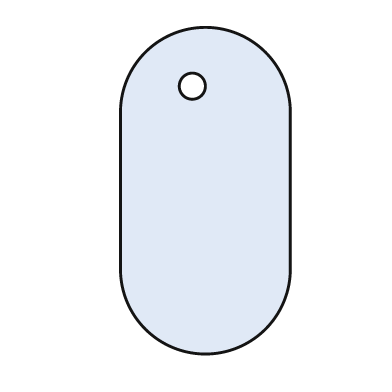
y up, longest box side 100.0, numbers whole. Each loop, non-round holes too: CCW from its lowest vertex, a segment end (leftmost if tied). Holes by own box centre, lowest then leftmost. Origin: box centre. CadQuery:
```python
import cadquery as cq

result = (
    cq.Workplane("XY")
    .moveTo(-26.0, -24.0)
    .threePointArc((0.0, -50.0), (26.0, -24.0))
    .lineTo(26.0, 24.0)
    .threePointArc((0.0, 50.0), (-26.0, 24.0))
    .close()
    .moveTo(-4.0, 32.0)
    .circle(4.0)
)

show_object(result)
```